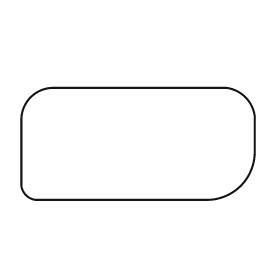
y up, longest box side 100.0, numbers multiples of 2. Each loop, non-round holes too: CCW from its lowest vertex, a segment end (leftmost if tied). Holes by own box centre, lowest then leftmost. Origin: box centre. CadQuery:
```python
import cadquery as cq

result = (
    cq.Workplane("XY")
    .moveTo(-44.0, -24.0)
    .lineTo(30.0, -24.0)
    .threePointArc((44.0, -18.0), (50.0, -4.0))
    .lineTo(50.0, 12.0)
    .threePointArc((46.0, 20.0), (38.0, 24.0))
    .lineTo(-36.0, 24.0)
    .threePointArc((-46.0, 20.0), (-50.0, 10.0))
    .lineTo(-50.0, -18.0)
    .threePointArc((-48.0, -22.0), (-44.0, -24.0))
    .close()
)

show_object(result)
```